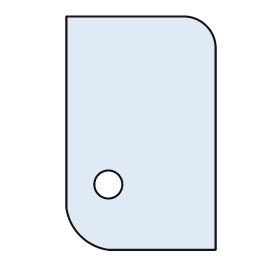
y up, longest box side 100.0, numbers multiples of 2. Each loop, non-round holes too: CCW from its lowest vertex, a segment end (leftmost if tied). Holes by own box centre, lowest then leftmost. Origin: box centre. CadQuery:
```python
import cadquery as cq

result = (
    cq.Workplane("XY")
    .moveTo(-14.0, -50.0)
    .lineTo(32.0, -50.0)
    .lineTo(32.0, 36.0)
    .threePointArc((28.0, 46.0), (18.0, 50.0))
    .lineTo(-32.0, 50.0)
    .lineTo(-32.0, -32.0)
    .threePointArc((-26.0, -44.0), (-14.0, -50.0))
    .close()
    .moveTo(-14.0, -22.0)
    .circle(6.0)
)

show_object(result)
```